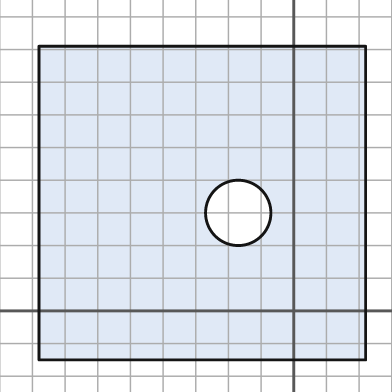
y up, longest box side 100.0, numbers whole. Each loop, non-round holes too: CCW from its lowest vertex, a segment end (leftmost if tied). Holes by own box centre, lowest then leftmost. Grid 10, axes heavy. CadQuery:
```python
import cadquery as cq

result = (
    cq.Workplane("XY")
    .moveTo(-78.0, -15.0)
    .lineTo(22.0, -15.0)
    .lineTo(22.0, 81.0)
    .lineTo(-78.0, 81.0)
    .close()
    .moveTo(-17.0, 30.0)
    .circle(10.0)
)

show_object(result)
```